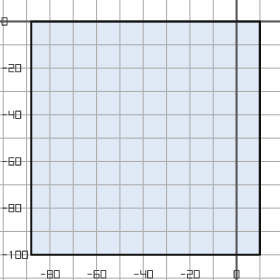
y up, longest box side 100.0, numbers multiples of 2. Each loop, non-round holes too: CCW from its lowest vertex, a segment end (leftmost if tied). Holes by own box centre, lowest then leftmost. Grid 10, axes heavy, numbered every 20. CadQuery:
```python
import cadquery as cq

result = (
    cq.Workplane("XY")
    .moveTo(-88.0, -100.0)
    .lineTo(10.0, -100.0)
    .lineTo(10.0, 0.0)
    .lineTo(-88.0, 0.0)
    .close()
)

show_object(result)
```